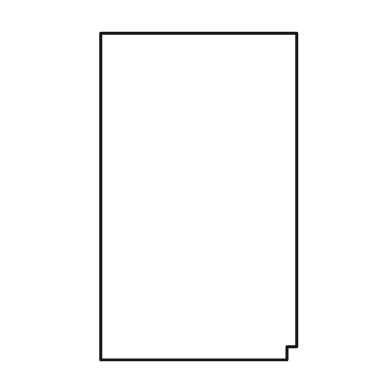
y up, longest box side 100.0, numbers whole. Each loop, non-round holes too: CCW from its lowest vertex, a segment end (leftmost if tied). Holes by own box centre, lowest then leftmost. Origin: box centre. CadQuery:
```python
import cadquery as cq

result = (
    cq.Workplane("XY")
    .moveTo(-30.0, -50.0)
    .lineTo(27.0, -50.0)
    .lineTo(27.0, -46.0)
    .lineTo(30.0, -46.0)
    .lineTo(30.0, 50.0)
    .lineTo(-30.0, 50.0)
    .close()
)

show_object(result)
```